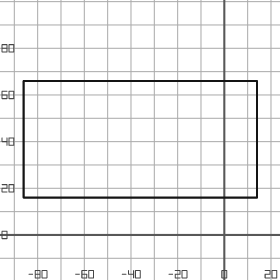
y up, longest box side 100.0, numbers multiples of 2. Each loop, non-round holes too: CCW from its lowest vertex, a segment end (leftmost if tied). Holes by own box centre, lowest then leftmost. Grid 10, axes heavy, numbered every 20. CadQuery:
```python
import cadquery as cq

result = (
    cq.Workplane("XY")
    .moveTo(-86.0, 16.0)
    .lineTo(14.0, 16.0)
    .lineTo(14.0, 66.0)
    .lineTo(-86.0, 66.0)
    .close()
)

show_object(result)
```